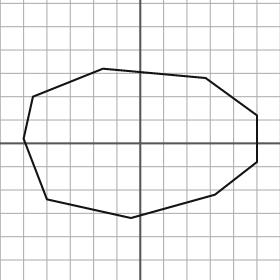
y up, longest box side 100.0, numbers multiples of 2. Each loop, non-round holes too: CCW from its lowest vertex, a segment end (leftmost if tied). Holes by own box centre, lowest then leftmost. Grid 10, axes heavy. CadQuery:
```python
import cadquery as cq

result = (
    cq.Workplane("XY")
    .moveTo(-4.0, -32.0)
    .lineTo(32.0, -22.0)
    .lineTo(50.0, -8.0)
    .lineTo(50.0, 12.0)
    .lineTo(28.0, 28.0)
    .lineTo(-16.0, 32.0)
    .lineTo(-46.0, 20.0)
    .lineTo(-50.0, 2.0)
    .lineTo(-40.0, -24.0)
    .close()
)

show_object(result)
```